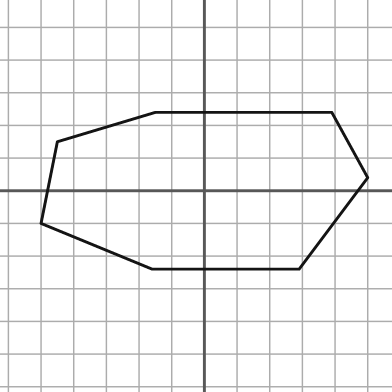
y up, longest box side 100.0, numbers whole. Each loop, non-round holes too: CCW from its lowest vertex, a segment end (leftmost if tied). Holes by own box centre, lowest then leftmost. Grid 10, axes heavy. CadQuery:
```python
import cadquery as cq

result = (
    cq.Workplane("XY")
    .moveTo(-16.0, -24.0)
    .lineTo(29.0, -24.0)
    .lineTo(50.0, 4.0)
    .lineTo(39.0, 24.0)
    .lineTo(-15.0, 24.0)
    .lineTo(-45.0, 15.0)
    .lineTo(-50.0, -10.0)
    .close()
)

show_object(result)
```